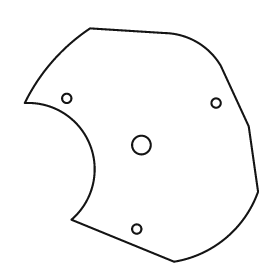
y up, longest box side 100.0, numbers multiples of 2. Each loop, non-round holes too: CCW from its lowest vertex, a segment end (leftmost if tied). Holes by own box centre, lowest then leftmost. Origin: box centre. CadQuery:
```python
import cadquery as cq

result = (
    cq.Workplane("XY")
    .moveTo(14.0, -50.0)
    .threePointArc((36.0, -40.0), (50.0, -20.0))
    .lineTo(46.0, 8.0)
    .lineTo(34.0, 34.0)
    .threePointArc((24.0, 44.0), (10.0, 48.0))
    .lineTo(-22.0, 50.0)
    .threePointArc((-38.0, 36.0), (-50.0, 18.0))
    .threePointArc((-22.0, 0.0), (-30.0, -32.0))
    .close()
    .moveTo(-2.0, -36.0)
    .circle(2.0)
    .moveTo(0.0, 0.0)
    .circle(4.0)
    .moveTo(32.0, 18.0)
    .circle(2.0)
    .moveTo(-32.0, 20.0)
    .circle(2.0)
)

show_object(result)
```